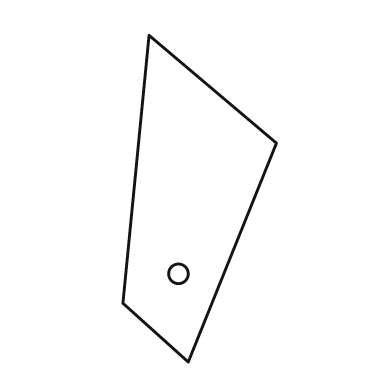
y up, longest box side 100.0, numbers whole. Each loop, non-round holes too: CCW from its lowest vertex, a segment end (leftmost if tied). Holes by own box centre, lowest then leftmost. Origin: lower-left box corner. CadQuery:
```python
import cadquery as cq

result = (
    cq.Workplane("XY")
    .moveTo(20.0, 0.0)
    .lineTo(47.0, 67.0)
    .lineTo(8.0, 100.0)
    .lineTo(0.0, 18.0)
    .close()
    .moveTo(17.0, 27.0)
    .circle(3.0)
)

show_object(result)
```